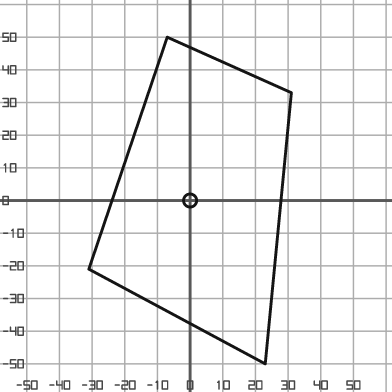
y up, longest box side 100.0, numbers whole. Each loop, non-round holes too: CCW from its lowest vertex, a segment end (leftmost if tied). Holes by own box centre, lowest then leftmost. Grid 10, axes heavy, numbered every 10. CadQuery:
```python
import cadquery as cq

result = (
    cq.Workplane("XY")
    .moveTo(23.0, -50.0)
    .lineTo(31.0, 33.0)
    .lineTo(-7.0, 50.0)
    .lineTo(-31.0, -21.0)
    .close()
    .moveTo(0.0, 0.0)
    .circle(2.0)
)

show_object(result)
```